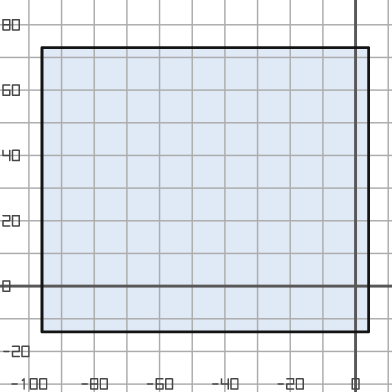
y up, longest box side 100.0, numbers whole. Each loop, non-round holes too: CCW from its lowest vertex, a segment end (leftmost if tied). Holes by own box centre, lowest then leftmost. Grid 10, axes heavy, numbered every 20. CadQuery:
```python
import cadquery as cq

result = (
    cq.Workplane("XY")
    .moveTo(-96.0, -14.0)
    .lineTo(4.0, -14.0)
    .lineTo(4.0, 73.0)
    .lineTo(-96.0, 73.0)
    .close()
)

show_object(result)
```